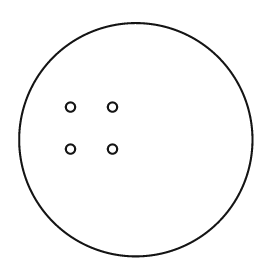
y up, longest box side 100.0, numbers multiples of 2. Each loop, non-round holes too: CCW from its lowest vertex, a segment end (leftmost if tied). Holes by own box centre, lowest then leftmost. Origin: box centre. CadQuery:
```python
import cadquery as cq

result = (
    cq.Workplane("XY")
    .moveTo(0.0, 0.0)
    .circle(50.0)
    .moveTo(-28.0, -4.0)
    .circle(2.0)
    .moveTo(-10.0, -4.0)
    .circle(2.0)
    .moveTo(-28.0, 14.0)
    .circle(2.0)
    .moveTo(-10.0, 14.0)
    .circle(2.0)
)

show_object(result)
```